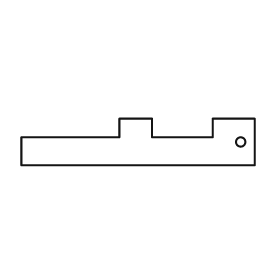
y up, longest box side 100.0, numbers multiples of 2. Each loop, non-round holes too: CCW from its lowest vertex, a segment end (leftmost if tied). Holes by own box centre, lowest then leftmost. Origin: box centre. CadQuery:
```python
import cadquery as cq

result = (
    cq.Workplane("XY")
    .moveTo(-50.0, -10.0)
    .lineTo(50.0, -10.0)
    .lineTo(50.0, 10.0)
    .lineTo(32.0, 10.0)
    .lineTo(32.0, 2.0)
    .lineTo(6.0, 2.0)
    .lineTo(6.0, 10.0)
    .lineTo(-8.0, 10.0)
    .lineTo(-8.0, 2.0)
    .lineTo(-50.0, 2.0)
    .close()
    .moveTo(44.0, 0.0)
    .circle(2.0)
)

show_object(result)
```